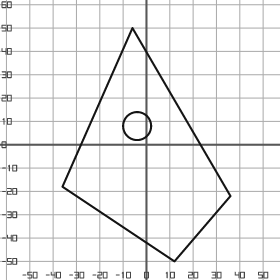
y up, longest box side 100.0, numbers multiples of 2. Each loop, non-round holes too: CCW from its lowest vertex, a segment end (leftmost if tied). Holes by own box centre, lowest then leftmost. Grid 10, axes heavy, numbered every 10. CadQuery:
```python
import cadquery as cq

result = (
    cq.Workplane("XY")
    .moveTo(12.0, -50.0)
    .lineTo(36.0, -22.0)
    .lineTo(-6.0, 50.0)
    .lineTo(-36.0, -18.0)
    .close()
    .moveTo(-4.0, 8.0)
    .circle(6.0)
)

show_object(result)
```